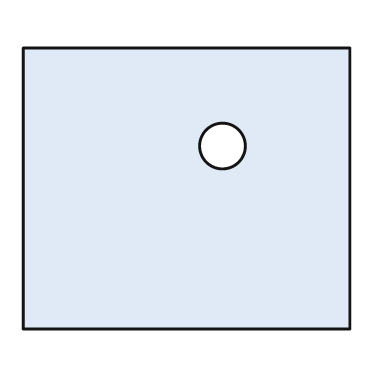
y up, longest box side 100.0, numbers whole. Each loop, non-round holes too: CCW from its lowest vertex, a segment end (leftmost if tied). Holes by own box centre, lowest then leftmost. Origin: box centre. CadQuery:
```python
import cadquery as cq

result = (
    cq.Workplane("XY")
    .moveTo(-50.0, -43.0)
    .lineTo(50.0, -43.0)
    .lineTo(50.0, 43.0)
    .lineTo(-50.0, 43.0)
    .close()
    .moveTo(11.0, 13.0)
    .circle(7.0)
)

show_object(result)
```